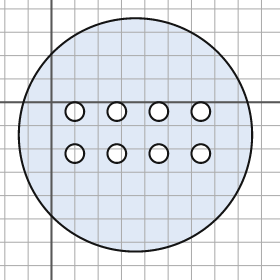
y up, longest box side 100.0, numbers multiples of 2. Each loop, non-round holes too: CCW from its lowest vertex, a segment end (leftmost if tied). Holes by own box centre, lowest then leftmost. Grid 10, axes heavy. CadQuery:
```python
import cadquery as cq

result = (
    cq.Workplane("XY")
    .moveTo(36.0, -14.0)
    .circle(50.0)
    .moveTo(10.0, -22.0)
    .circle(4.0)
    .moveTo(28.0, -22.0)
    .circle(4.0)
    .moveTo(46.0, -22.0)
    .circle(4.0)
    .moveTo(64.0, -22.0)
    .circle(4.0)
    .moveTo(10.0, -4.0)
    .circle(4.0)
    .moveTo(28.0, -4.0)
    .circle(4.0)
    .moveTo(46.0, -4.0)
    .circle(4.0)
    .moveTo(64.0, -4.0)
    .circle(4.0)
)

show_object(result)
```